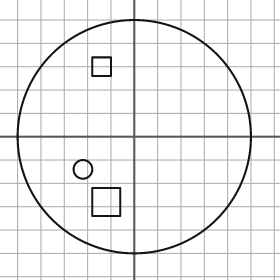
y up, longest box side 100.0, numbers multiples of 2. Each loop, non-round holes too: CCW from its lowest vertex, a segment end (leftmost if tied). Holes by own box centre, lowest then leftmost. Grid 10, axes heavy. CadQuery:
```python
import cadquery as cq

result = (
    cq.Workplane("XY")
    .moveTo(0.0, 0.0)
    .circle(50.0)
    .moveTo(-18.0, -34.0)
    .lineTo(-6.0, -34.0)
    .lineTo(-6.0, -22.0)
    .lineTo(-18.0, -22.0)
    .close()
    .moveTo(-22.0, -14.0)
    .circle(4.0)
    .moveTo(-18.0, 26.0)
    .lineTo(-10.0, 26.0)
    .lineTo(-10.0, 34.0)
    .lineTo(-18.0, 34.0)
    .close()
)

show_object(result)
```